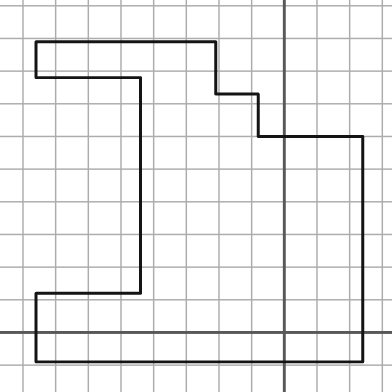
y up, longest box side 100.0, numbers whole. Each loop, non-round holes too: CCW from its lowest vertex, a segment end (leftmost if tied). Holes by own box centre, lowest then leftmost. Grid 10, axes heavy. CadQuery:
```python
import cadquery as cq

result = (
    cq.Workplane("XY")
    .moveTo(-76.0, -9.0)
    .lineTo(24.0, -9.0)
    .lineTo(24.0, 60.0)
    .lineTo(-8.0, 60.0)
    .lineTo(-8.0, 73.0)
    .lineTo(-21.0, 73.0)
    .lineTo(-21.0, 89.0)
    .lineTo(-76.0, 89.0)
    .lineTo(-76.0, 78.0)
    .lineTo(-44.0, 78.0)
    .lineTo(-44.0, 12.0)
    .lineTo(-76.0, 12.0)
    .close()
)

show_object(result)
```